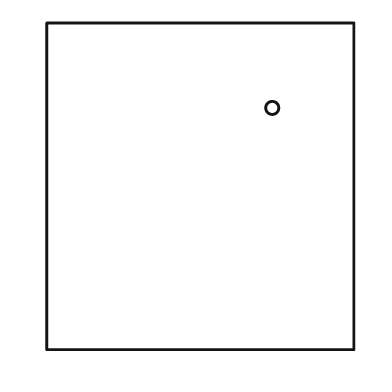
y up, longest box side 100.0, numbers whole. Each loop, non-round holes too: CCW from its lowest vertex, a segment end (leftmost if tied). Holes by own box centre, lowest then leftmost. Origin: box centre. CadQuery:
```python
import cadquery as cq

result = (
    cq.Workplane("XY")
    .moveTo(-47.0, -50.0)
    .lineTo(47.0, -50.0)
    .lineTo(47.0, 50.0)
    .lineTo(-47.0, 50.0)
    .close()
    .moveTo(22.0, 24.0)
    .circle(2.0)
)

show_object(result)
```